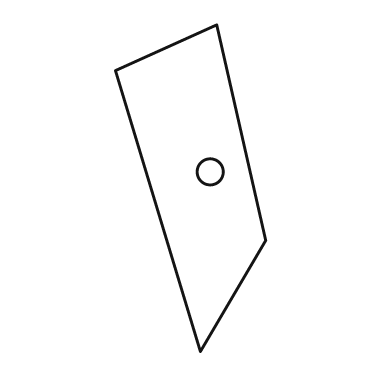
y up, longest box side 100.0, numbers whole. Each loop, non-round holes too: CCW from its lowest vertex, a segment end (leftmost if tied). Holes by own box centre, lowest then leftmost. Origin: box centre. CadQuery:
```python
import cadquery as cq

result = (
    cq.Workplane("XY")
    .moveTo(3.0, -50.0)
    .lineTo(23.0, -16.0)
    .lineTo(8.0, 50.0)
    .lineTo(-23.0, 36.0)
    .close()
    .moveTo(6.0, 5.0)
    .circle(4.0)
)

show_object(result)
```